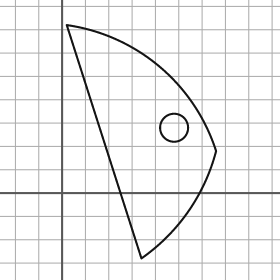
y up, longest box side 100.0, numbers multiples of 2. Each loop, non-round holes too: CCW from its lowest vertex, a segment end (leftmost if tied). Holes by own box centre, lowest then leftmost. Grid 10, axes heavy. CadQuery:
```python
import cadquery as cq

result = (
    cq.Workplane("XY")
    .moveTo(34.0, -28.0)
    .threePointArc((54.0, -8.0), (66.0, 18.0))
    .threePointArc((42.0, 54.0), (2.0, 72.0))
    .close()
    .moveTo(48.0, 28.0)
    .circle(6.0)
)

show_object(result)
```